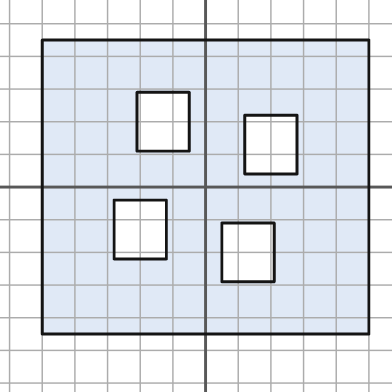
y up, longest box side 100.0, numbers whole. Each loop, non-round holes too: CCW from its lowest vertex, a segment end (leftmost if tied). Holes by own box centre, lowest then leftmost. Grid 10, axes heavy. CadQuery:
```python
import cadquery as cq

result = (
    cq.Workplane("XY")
    .moveTo(-50.0, -45.0)
    .lineTo(50.0, -45.0)
    .lineTo(50.0, 45.0)
    .lineTo(-50.0, 45.0)
    .close()
    .moveTo(5.0, -29.0)
    .lineTo(21.0, -29.0)
    .lineTo(21.0, -11.0)
    .lineTo(5.0, -11.0)
    .close()
    .moveTo(-28.0, -22.0)
    .lineTo(-12.0, -22.0)
    .lineTo(-12.0, -4.0)
    .lineTo(-28.0, -4.0)
    .close()
    .moveTo(12.0, 4.0)
    .lineTo(28.0, 4.0)
    .lineTo(28.0, 22.0)
    .lineTo(12.0, 22.0)
    .close()
    .moveTo(-21.0, 11.0)
    .lineTo(-5.0, 11.0)
    .lineTo(-5.0, 29.0)
    .lineTo(-21.0, 29.0)
    .close()
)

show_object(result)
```